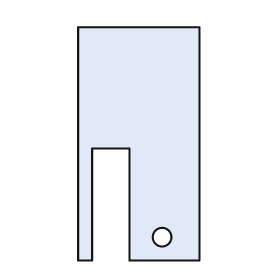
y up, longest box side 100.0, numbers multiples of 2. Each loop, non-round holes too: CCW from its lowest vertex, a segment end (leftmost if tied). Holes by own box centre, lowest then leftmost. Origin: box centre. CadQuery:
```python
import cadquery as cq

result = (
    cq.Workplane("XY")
    .moveTo(-26.0, -50.0)
    .lineTo(-20.0, -50.0)
    .lineTo(-20.0, -2.0)
    .lineTo(-4.0, -2.0)
    .lineTo(-4.0, -50.0)
    .lineTo(26.0, -50.0)
    .lineTo(26.0, 50.0)
    .lineTo(-26.0, 50.0)
    .close()
    .moveTo(10.0, -40.0)
    .circle(4.0)
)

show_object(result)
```